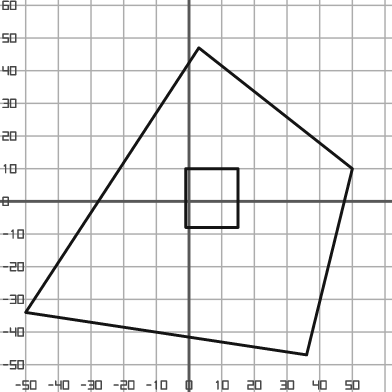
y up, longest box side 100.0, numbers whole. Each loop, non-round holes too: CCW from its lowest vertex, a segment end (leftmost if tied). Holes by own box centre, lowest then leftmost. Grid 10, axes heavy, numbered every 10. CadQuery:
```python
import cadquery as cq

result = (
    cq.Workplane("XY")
    .moveTo(36.0, -47.0)
    .lineTo(50.0, 10.0)
    .lineTo(3.0, 47.0)
    .lineTo(-50.0, -34.0)
    .close()
    .moveTo(-1.0, -8.0)
    .lineTo(15.0, -8.0)
    .lineTo(15.0, 10.0)
    .lineTo(-1.0, 10.0)
    .close()
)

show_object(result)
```